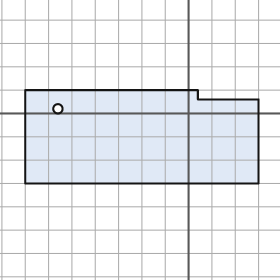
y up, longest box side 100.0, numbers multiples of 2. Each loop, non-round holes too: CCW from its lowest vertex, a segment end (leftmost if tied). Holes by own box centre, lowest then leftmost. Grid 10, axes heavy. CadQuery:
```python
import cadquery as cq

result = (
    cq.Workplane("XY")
    .moveTo(-70.0, -30.0)
    .lineTo(30.0, -30.0)
    .lineTo(30.0, 6.0)
    .lineTo(4.0, 6.0)
    .lineTo(4.0, 10.0)
    .lineTo(-70.0, 10.0)
    .close()
    .moveTo(-56.0, 2.0)
    .circle(2.0)
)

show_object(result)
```